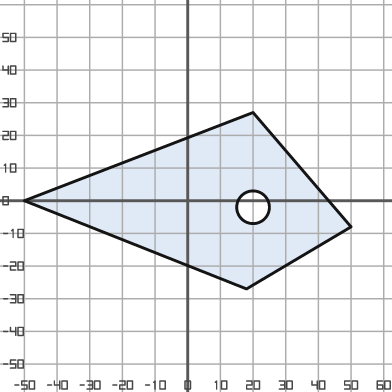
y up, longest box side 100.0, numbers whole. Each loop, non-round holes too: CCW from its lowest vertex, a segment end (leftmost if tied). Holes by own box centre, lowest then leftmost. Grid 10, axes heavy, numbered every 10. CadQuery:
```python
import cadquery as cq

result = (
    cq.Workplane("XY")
    .moveTo(18.0, -27.0)
    .lineTo(50.0, -8.0)
    .lineTo(20.0, 27.0)
    .lineTo(-50.0, 0.0)
    .close()
    .moveTo(20.0, -2.0)
    .circle(5.0)
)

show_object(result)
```